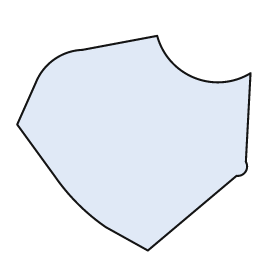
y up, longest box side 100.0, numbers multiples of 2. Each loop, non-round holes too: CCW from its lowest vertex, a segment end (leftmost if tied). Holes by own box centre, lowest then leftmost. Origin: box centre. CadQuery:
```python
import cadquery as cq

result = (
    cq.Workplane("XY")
    .moveTo(6.0, -46.0)
    .lineTo(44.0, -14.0)
    .threePointArc((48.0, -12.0), (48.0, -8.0))
    .lineTo(50.0, 30.0)
    .threePointArc((26.0, 28.0), (10.0, 46.0))
    .lineTo(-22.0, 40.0)
    .threePointArc((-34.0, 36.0), (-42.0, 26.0))
    .lineTo(-50.0, 8.0)
    .lineTo(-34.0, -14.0)
    .threePointArc((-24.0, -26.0), (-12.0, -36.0))
    .close()
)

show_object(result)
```